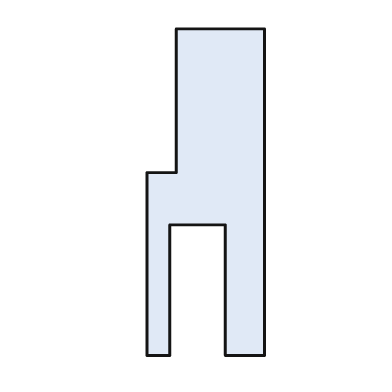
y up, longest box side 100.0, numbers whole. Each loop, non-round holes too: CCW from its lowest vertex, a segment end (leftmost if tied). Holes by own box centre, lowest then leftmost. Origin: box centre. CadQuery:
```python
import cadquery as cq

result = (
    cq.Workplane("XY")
    .moveTo(-18.0, -50.0)
    .lineTo(-11.0, -50.0)
    .lineTo(-11.0, -10.0)
    .lineTo(6.0, -10.0)
    .lineTo(6.0, -50.0)
    .lineTo(18.0, -50.0)
    .lineTo(18.0, 50.0)
    .lineTo(-9.0, 50.0)
    .lineTo(-9.0, 6.0)
    .lineTo(-18.0, 6.0)
    .close()
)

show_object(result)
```